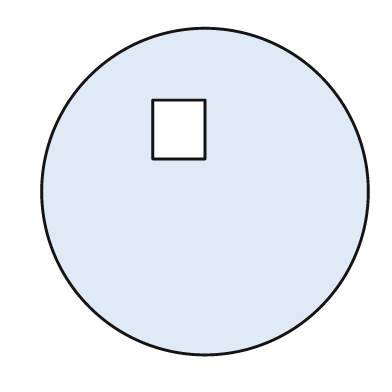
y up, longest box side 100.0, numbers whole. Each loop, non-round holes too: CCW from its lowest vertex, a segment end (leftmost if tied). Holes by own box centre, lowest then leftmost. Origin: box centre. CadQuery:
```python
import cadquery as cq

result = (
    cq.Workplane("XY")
    .moveTo(0.0, 0.0)
    .circle(50.0)
    .moveTo(-16.0, 10.0)
    .lineTo(0.0, 10.0)
    .lineTo(0.0, 28.0)
    .lineTo(-16.0, 28.0)
    .close()
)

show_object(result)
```